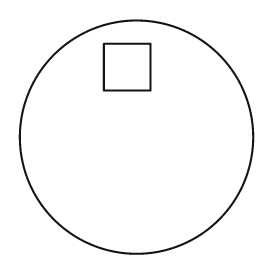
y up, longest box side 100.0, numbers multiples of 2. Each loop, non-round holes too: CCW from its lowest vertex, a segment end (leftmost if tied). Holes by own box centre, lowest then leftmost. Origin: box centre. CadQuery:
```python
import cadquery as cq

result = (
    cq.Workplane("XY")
    .moveTo(0.0, 0.0)
    .circle(50.0)
    .moveTo(-14.0, 20.0)
    .lineTo(6.0, 20.0)
    .lineTo(6.0, 40.0)
    .lineTo(-14.0, 40.0)
    .close()
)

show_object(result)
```